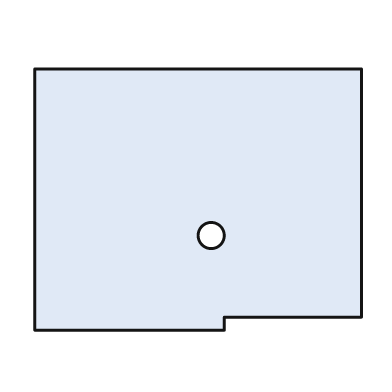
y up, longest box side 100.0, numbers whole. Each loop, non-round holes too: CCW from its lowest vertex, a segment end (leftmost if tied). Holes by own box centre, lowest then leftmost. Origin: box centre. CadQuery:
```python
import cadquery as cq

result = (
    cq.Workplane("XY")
    .moveTo(-50.0, -40.0)
    .lineTo(8.0, -40.0)
    .lineTo(8.0, -36.0)
    .lineTo(50.0, -36.0)
    .lineTo(50.0, 40.0)
    .lineTo(-50.0, 40.0)
    .close()
    .moveTo(4.0, -11.0)
    .circle(4.0)
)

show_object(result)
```